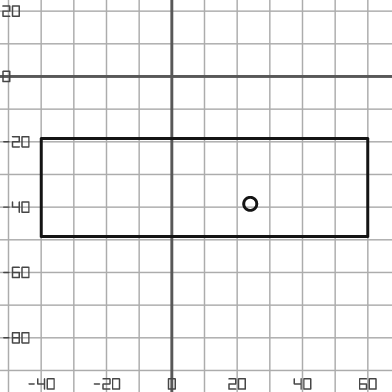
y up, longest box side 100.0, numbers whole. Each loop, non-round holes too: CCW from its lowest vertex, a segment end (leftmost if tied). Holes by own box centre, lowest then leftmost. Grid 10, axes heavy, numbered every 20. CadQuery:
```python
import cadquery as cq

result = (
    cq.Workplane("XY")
    .moveTo(-40.0, -49.0)
    .lineTo(60.0, -49.0)
    .lineTo(60.0, -19.0)
    .lineTo(-40.0, -19.0)
    .close()
    .moveTo(24.0, -39.0)
    .circle(2.0)
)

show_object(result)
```